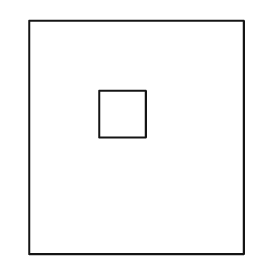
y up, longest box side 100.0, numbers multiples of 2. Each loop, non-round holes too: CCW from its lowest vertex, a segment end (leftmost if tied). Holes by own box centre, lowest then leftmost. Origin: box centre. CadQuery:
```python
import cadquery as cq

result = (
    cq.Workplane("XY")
    .moveTo(-46.0, -50.0)
    .lineTo(46.0, -50.0)
    .lineTo(46.0, 50.0)
    .lineTo(-46.0, 50.0)
    .close()
    .moveTo(-16.0, 0.0)
    .lineTo(4.0, 0.0)
    .lineTo(4.0, 20.0)
    .lineTo(-16.0, 20.0)
    .close()
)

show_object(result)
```